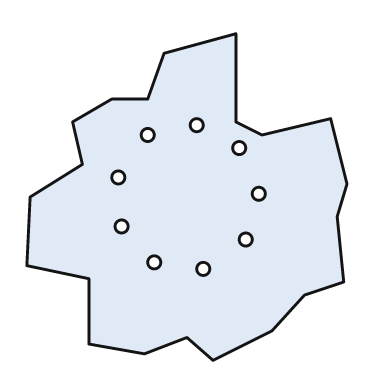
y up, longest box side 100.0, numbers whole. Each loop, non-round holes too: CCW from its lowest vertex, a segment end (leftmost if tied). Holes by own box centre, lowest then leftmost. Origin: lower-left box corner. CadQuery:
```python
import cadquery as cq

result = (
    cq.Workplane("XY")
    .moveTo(57.0, 0.0)
    .lineTo(75.0, 9.0)
    .lineTo(85.0, 20.0)
    .lineTo(97.0, 24.0)
    .lineTo(95.0, 44.0)
    .lineTo(98.0, 54.0)
    .lineTo(93.0, 74.0)
    .lineTo(72.0, 69.0)
    .lineTo(64.0, 73.0)
    .lineTo(64.0, 100.0)
    .lineTo(42.0, 94.0)
    .lineTo(37.0, 80.0)
    .lineTo(26.0, 80.0)
    .lineTo(14.0, 73.0)
    .lineTo(17.0, 60.0)
    .lineTo(1.0, 50.0)
    .lineTo(0.0, 29.0)
    .lineTo(19.0, 25.0)
    .lineTo(19.0, 5.0)
    .lineTo(36.0, 2.0)
    .lineTo(49.0, 7.0)
    .close()
    .moveTo(54.0, 28.0)
    .circle(2.0)
    .moveTo(39.0, 30.0)
    .circle(2.0)
    .moveTo(67.0, 37.0)
    .circle(2.0)
    .moveTo(29.0, 41.0)
    .circle(2.0)
    .moveTo(71.0, 51.0)
    .circle(2.0)
    .moveTo(28.0, 56.0)
    .circle(2.0)
    .moveTo(65.0, 65.0)
    .circle(2.0)
    .moveTo(37.0, 69.0)
    .circle(2.0)
    .moveTo(52.0, 72.0)
    .circle(2.0)
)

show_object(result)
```